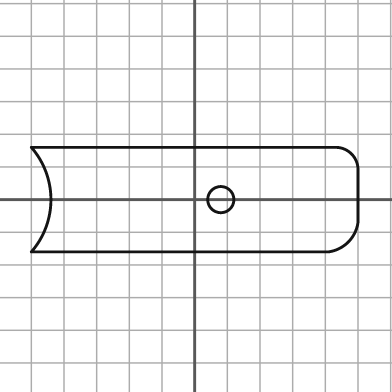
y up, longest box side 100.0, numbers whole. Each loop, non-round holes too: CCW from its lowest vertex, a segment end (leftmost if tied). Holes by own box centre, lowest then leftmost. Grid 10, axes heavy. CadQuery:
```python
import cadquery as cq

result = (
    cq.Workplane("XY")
    .moveTo(-50.0, -16.0)
    .lineTo(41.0, -16.0)
    .threePointArc((47.0, -13.0), (50.0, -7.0))
    .lineTo(50.0, 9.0)
    .threePointArc((48.0, 14.0), (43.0, 16.0))
    .lineTo(-50.0, 16.0)
    .threePointArc((-44.0, 0.0), (-50.0, -16.0))
    .close()
    .moveTo(8.0, 0.0)
    .circle(4.0)
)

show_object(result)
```